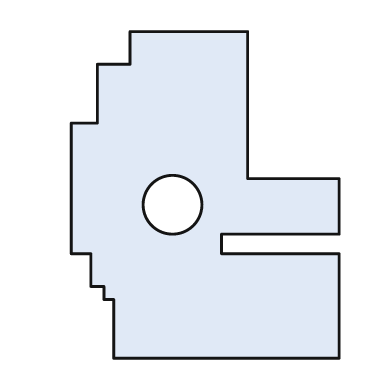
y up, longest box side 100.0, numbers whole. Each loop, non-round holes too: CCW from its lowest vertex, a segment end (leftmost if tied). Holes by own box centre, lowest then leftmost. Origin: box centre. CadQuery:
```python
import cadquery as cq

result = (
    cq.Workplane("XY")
    .moveTo(-28.0, -50.0)
    .lineTo(41.0, -50.0)
    .lineTo(41.0, -18.0)
    .lineTo(5.0, -18.0)
    .lineTo(5.0, -12.0)
    .lineTo(41.0, -12.0)
    .lineTo(41.0, 5.0)
    .lineTo(13.0, 5.0)
    .lineTo(13.0, 50.0)
    .lineTo(-23.0, 50.0)
    .lineTo(-23.0, 40.0)
    .lineTo(-33.0, 40.0)
    .lineTo(-33.0, 22.0)
    .lineTo(-41.0, 22.0)
    .lineTo(-41.0, -18.0)
    .lineTo(-35.0, -18.0)
    .lineTo(-35.0, -28.0)
    .lineTo(-31.0, -28.0)
    .lineTo(-31.0, -32.0)
    .lineTo(-28.0, -32.0)
    .close()
    .moveTo(-10.0, -3.0)
    .circle(9.0)
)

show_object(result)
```